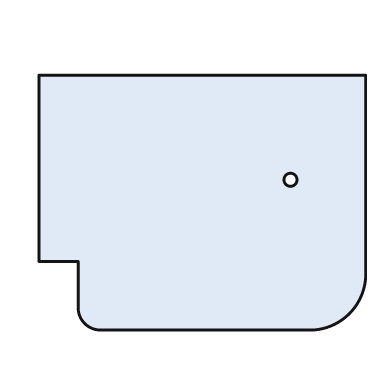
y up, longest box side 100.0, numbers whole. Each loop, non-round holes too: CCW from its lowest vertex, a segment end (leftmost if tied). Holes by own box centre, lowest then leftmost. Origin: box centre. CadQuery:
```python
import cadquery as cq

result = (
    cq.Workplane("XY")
    .moveTo(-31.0, -39.0)
    .lineTo(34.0, -39.0)
    .threePointArc((45.0, -34.0), (50.0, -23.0))
    .lineTo(50.0, 39.0)
    .lineTo(-50.0, 39.0)
    .lineTo(-50.0, -18.0)
    .lineTo(-38.0, -18.0)
    .lineTo(-38.0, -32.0)
    .threePointArc((-36.0, -37.0), (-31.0, -39.0))
    .close()
    .moveTo(27.0, 7.0)
    .circle(2.0)
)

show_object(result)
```